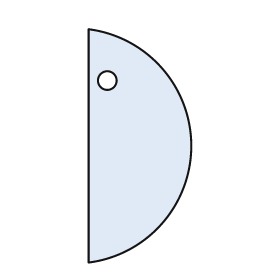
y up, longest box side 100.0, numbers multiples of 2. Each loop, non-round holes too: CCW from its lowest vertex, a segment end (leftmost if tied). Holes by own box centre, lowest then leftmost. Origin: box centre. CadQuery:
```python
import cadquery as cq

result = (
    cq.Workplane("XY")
    .moveTo(-22.0, -50.0)
    .threePointArc((22.0, 0.0), (-22.0, 50.0))
    .close()
    .moveTo(-14.0, 28.0)
    .circle(4.0)
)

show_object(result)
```